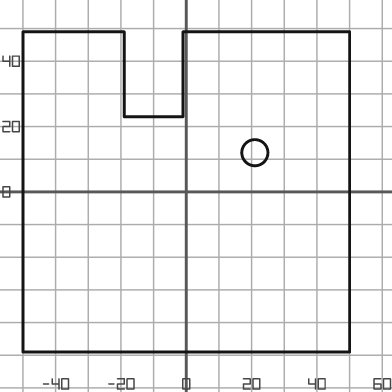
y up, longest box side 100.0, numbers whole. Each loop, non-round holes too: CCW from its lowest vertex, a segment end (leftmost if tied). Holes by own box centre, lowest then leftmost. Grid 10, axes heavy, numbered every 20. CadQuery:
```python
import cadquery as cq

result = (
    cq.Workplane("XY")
    .moveTo(-50.0, -49.0)
    .lineTo(50.0, -49.0)
    .lineTo(50.0, 49.0)
    .lineTo(-1.0, 49.0)
    .lineTo(-1.0, 23.0)
    .lineTo(-19.0, 23.0)
    .lineTo(-19.0, 49.0)
    .lineTo(-50.0, 49.0)
    .close()
    .moveTo(21.0, 12.0)
    .circle(4.0)
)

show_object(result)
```